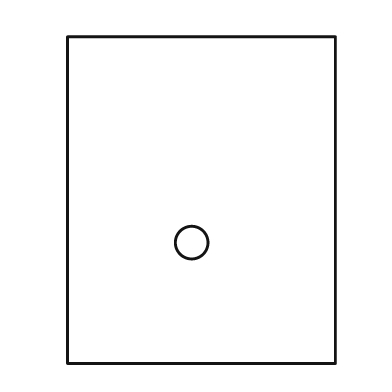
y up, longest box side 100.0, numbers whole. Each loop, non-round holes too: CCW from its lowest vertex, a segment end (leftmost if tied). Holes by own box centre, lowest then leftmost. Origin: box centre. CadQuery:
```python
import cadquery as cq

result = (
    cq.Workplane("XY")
    .moveTo(-41.0, -50.0)
    .lineTo(41.0, -50.0)
    .lineTo(41.0, 50.0)
    .lineTo(-41.0, 50.0)
    .close()
    .moveTo(-3.0, -13.0)
    .circle(5.0)
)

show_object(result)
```